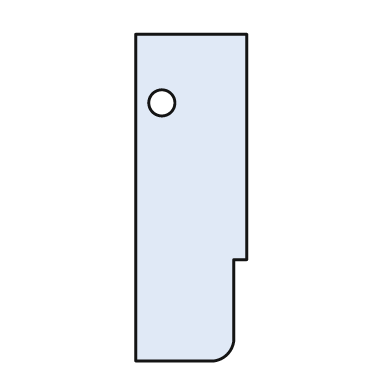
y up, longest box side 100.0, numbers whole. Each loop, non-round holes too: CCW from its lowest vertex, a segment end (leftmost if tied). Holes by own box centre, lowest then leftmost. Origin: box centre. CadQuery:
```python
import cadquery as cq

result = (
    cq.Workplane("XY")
    .moveTo(-17.0, -50.0)
    .lineTo(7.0, -50.0)
    .threePointArc((11.0, -48.0), (13.0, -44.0))
    .lineTo(13.0, -19.0)
    .lineTo(17.0, -19.0)
    .lineTo(17.0, 50.0)
    .lineTo(-17.0, 50.0)
    .close()
    .moveTo(-9.0, 29.0)
    .circle(4.0)
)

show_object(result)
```